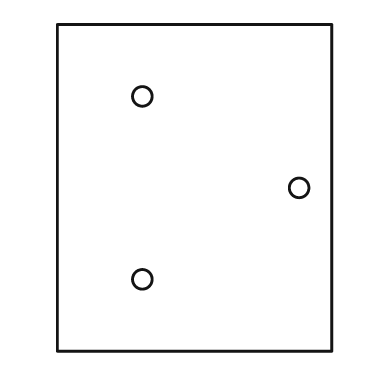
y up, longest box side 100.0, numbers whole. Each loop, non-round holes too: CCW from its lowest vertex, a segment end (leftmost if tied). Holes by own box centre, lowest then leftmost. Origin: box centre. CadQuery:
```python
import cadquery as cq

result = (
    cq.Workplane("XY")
    .moveTo(-42.0, -50.0)
    .lineTo(42.0, -50.0)
    .lineTo(42.0, 50.0)
    .lineTo(-42.0, 50.0)
    .close()
    .moveTo(-16.0, -28.0)
    .circle(3.0)
    .moveTo(32.0, 0.0)
    .circle(3.0)
    .moveTo(-16.0, 28.0)
    .circle(3.0)
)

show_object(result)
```